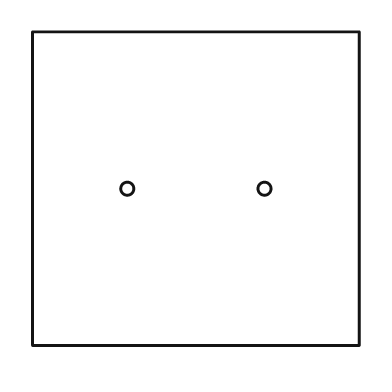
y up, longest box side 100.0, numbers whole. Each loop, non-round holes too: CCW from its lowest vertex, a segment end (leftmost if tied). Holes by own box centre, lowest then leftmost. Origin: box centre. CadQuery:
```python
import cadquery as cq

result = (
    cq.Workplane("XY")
    .moveTo(-50.0, -48.0)
    .lineTo(50.0, -48.0)
    .lineTo(50.0, 48.0)
    .lineTo(-50.0, 48.0)
    .close()
    .moveTo(-21.0, 0.0)
    .circle(2.0)
    .moveTo(21.0, 0.0)
    .circle(2.0)
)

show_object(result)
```